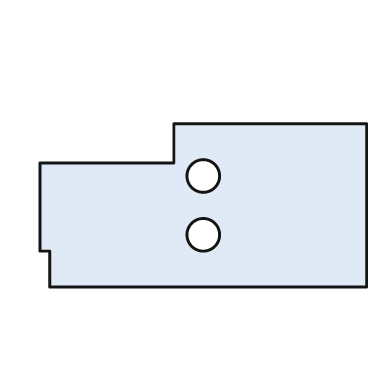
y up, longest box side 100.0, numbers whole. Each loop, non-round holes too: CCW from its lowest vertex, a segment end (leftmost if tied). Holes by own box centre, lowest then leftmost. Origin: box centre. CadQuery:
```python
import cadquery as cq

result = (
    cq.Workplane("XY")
    .moveTo(-47.0, -25.0)
    .lineTo(50.0, -25.0)
    .lineTo(50.0, 25.0)
    .lineTo(-9.0, 25.0)
    .lineTo(-9.0, 13.0)
    .lineTo(-50.0, 13.0)
    .lineTo(-50.0, -14.0)
    .lineTo(-47.0, -14.0)
    .close()
    .moveTo(0.0, -9.0)
    .circle(5.0)
    .moveTo(0.0, 9.0)
    .circle(5.0)
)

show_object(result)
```